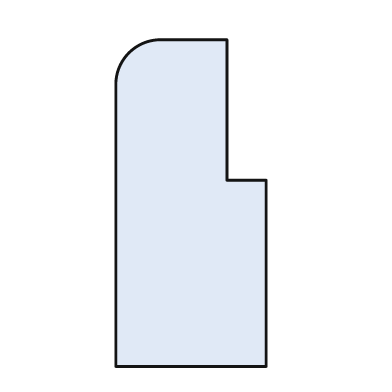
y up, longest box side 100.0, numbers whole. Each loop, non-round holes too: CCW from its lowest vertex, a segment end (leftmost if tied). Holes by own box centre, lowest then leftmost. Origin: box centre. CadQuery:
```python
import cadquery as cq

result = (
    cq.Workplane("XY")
    .moveTo(-23.0, -50.0)
    .lineTo(23.0, -50.0)
    .lineTo(23.0, 7.0)
    .lineTo(11.0, 7.0)
    .lineTo(11.0, 50.0)
    .lineTo(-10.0, 50.0)
    .threePointArc((-19.0, 46.0), (-23.0, 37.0))
    .close()
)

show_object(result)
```